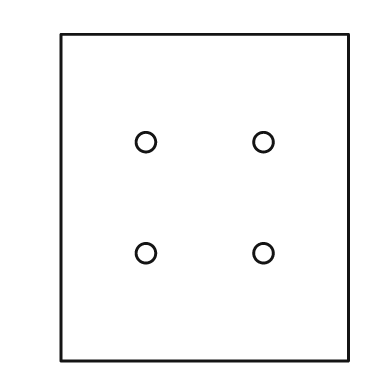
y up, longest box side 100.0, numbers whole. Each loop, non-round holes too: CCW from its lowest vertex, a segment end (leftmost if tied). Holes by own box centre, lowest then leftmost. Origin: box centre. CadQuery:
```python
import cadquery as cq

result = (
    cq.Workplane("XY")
    .moveTo(-44.0, -50.0)
    .lineTo(44.0, -50.0)
    .lineTo(44.0, 50.0)
    .lineTo(-44.0, 50.0)
    .close()
    .moveTo(-18.0, -17.0)
    .circle(3.0)
    .moveTo(18.0, -17.0)
    .circle(3.0)
    .moveTo(-18.0, 17.0)
    .circle(3.0)
    .moveTo(18.0, 17.0)
    .circle(3.0)
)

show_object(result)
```